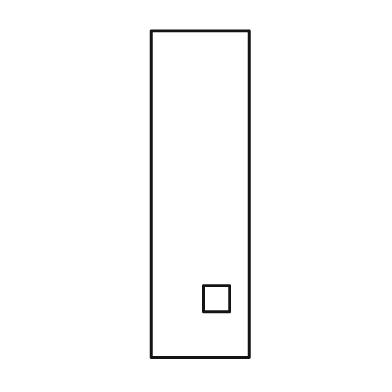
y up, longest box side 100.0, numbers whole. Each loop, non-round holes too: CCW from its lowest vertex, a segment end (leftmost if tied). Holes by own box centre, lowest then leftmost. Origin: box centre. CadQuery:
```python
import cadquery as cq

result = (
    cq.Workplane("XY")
    .moveTo(-15.0, -50.0)
    .lineTo(15.0, -50.0)
    .lineTo(15.0, 50.0)
    .lineTo(-15.0, 50.0)
    .close()
    .moveTo(1.0, -36.0)
    .lineTo(9.0, -36.0)
    .lineTo(9.0, -28.0)
    .lineTo(1.0, -28.0)
    .close()
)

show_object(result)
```